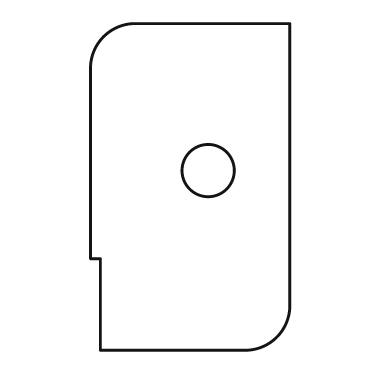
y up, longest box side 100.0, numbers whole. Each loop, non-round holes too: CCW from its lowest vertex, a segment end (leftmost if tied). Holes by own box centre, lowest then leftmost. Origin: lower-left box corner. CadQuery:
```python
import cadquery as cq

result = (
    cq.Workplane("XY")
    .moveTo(3.0, 0.0)
    .lineTo(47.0, 0.0)
    .threePointArc((57.0, 4.0), (61.0, 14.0))
    .lineTo(61.0, 100.0)
    .lineTo(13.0, 100.0)
    .threePointArc((4.0, 96.0), (0.0, 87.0))
    .lineTo(0.0, 28.0)
    .lineTo(3.0, 28.0)
    .close()
    .moveTo(36.0, 55.0)
    .circle(8.0)
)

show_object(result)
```